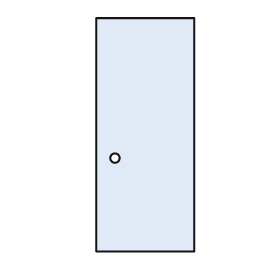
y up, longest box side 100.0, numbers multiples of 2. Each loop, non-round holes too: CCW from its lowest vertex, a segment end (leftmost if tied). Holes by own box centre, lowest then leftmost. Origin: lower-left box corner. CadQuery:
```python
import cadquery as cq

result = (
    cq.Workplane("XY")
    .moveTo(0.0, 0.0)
    .lineTo(42.0, 0.0)
    .lineTo(42.0, 100.0)
    .lineTo(0.0, 100.0)
    .close()
    .moveTo(8.0, 40.0)
    .circle(2.0)
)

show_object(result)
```